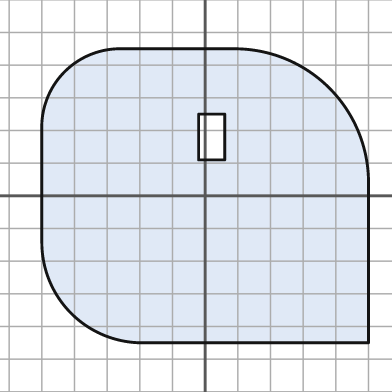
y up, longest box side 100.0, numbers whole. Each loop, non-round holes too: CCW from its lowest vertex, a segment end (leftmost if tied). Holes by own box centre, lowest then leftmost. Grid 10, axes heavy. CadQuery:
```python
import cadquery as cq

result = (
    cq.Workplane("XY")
    .moveTo(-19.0, -45.0)
    .lineTo(50.0, -45.0)
    .lineTo(50.0, 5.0)
    .threePointArc((38.0, 33.0), (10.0, 45.0))
    .lineTo(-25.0, 45.0)
    .threePointArc((-43.0, 38.0), (-50.0, 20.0))
    .lineTo(-50.0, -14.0)
    .threePointArc((-41.0, -36.0), (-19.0, -45.0))
    .close()
    .moveTo(-2.0, 11.0)
    .lineTo(6.0, 11.0)
    .lineTo(6.0, 25.0)
    .lineTo(-2.0, 25.0)
    .close()
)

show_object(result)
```